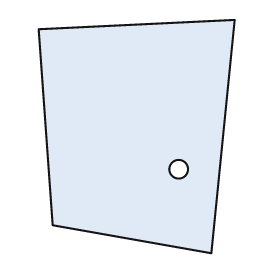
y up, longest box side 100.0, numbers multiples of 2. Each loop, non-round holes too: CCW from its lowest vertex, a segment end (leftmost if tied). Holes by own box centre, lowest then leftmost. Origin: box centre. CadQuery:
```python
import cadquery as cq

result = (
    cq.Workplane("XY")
    .moveTo(32.0, -50.0)
    .lineTo(42.0, 50.0)
    .lineTo(-42.0, 46.0)
    .lineTo(-36.0, -38.0)
    .close()
    .moveTo(18.0, -14.0)
    .circle(4.0)
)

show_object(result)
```